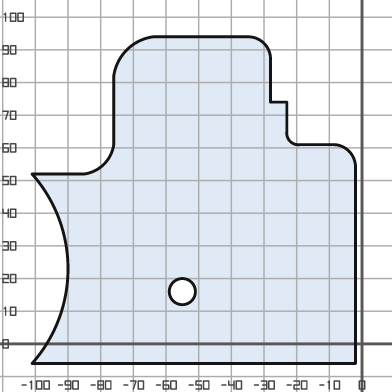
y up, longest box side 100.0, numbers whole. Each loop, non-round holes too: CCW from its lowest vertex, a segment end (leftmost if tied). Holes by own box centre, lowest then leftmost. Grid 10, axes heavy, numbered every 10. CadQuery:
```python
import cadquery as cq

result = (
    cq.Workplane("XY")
    .moveTo(-101.0, -6.0)
    .lineTo(-2.0, -6.0)
    .lineTo(-2.0, 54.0)
    .threePointArc((-4.0, 59.0), (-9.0, 61.0))
    .lineTo(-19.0, 61.0)
    .threePointArc((-22.0, 62.0), (-23.0, 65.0))
    .lineTo(-23.0, 74.0)
    .lineTo(-28.0, 74.0)
    .lineTo(-28.0, 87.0)
    .threePointArc((-30.0, 92.0), (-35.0, 94.0))
    .lineTo(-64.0, 94.0)
    .threePointArc((-72.0, 90.0), (-76.0, 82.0))
    .lineTo(-76.0, 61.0)
    .threePointArc((-79.0, 55.0), (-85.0, 52.0))
    .lineTo(-101.0, 52.0)
    .threePointArc((-90.0, 23.0), (-101.0, -6.0))
    .close()
    .moveTo(-55.0, 16.0)
    .circle(4.0)
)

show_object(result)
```